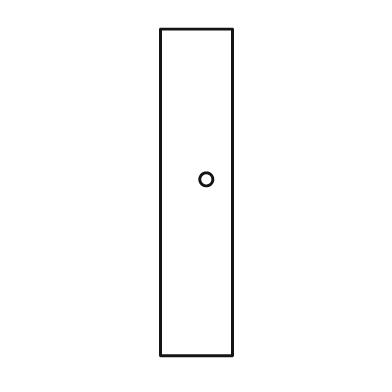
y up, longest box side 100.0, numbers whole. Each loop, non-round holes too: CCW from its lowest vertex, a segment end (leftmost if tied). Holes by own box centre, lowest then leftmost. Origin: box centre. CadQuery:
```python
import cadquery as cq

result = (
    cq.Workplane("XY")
    .moveTo(-11.0, -50.0)
    .lineTo(11.0, -50.0)
    .lineTo(11.0, 50.0)
    .lineTo(-11.0, 50.0)
    .close()
    .moveTo(3.0, 4.0)
    .circle(2.0)
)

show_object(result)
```